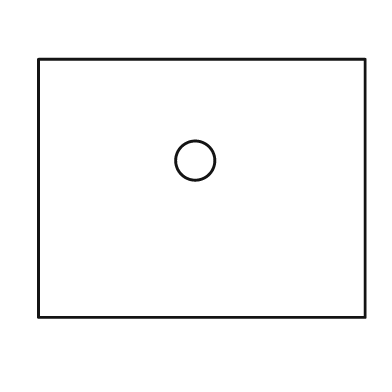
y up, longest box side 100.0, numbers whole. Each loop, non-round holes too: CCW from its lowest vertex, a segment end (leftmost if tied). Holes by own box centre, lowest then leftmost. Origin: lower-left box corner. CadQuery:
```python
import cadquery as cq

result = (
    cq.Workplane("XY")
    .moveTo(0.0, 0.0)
    .lineTo(100.0, 0.0)
    .lineTo(100.0, 79.0)
    .lineTo(0.0, 79.0)
    .close()
    .moveTo(48.0, 48.0)
    .circle(6.0)
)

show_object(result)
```